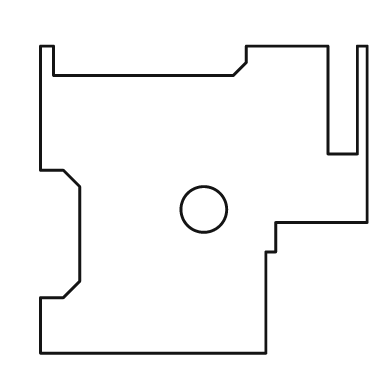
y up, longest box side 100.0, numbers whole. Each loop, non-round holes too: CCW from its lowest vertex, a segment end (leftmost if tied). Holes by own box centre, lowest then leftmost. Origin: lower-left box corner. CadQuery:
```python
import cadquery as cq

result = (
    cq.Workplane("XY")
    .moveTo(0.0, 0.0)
    .lineTo(69.0, 0.0)
    .lineTo(69.0, 31.0)
    .lineTo(72.0, 31.0)
    .lineTo(72.0, 40.0)
    .lineTo(100.0, 40.0)
    .lineTo(100.0, 94.0)
    .lineTo(97.0, 94.0)
    .lineTo(97.0, 61.0)
    .lineTo(88.0, 61.0)
    .lineTo(88.0, 94.0)
    .lineTo(63.0, 94.0)
    .lineTo(63.0, 89.0)
    .lineTo(59.0, 85.0)
    .lineTo(4.0, 85.0)
    .lineTo(4.0, 94.0)
    .lineTo(0.0, 94.0)
    .lineTo(0.0, 56.0)
    .lineTo(7.0, 56.0)
    .lineTo(12.0, 51.0)
    .lineTo(12.0, 22.0)
    .lineTo(7.0, 17.0)
    .lineTo(0.0, 17.0)
    .close()
    .moveTo(50.0, 44.0)
    .circle(7.0)
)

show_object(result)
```